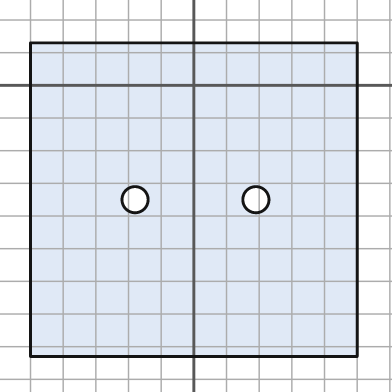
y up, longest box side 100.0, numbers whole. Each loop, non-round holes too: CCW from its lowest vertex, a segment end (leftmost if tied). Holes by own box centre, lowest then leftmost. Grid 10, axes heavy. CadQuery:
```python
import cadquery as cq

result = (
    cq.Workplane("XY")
    .moveTo(-50.0, -83.0)
    .lineTo(50.0, -83.0)
    .lineTo(50.0, 13.0)
    .lineTo(-50.0, 13.0)
    .close()
    .moveTo(-18.0, -35.0)
    .circle(4.0)
    .moveTo(19.0, -35.0)
    .circle(4.0)
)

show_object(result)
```